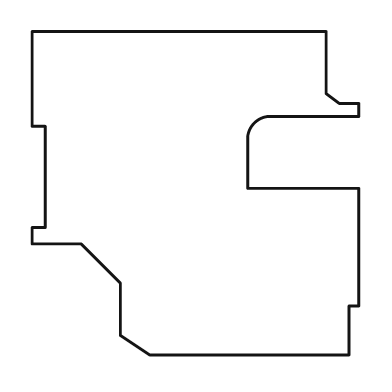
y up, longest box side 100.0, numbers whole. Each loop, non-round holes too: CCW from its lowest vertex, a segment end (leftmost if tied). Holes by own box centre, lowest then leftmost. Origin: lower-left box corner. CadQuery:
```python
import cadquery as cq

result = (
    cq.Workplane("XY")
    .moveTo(36.0, 0.0)
    .lineTo(97.0, 0.0)
    .lineTo(97.0, 15.0)
    .lineTo(100.0, 15.0)
    .lineTo(100.0, 51.0)
    .lineTo(66.0, 51.0)
    .lineTo(66.0, 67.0)
    .threePointArc((68.0, 71.0), (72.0, 73.0))
    .lineTo(100.0, 73.0)
    .lineTo(100.0, 77.0)
    .lineTo(94.0, 77.0)
    .lineTo(90.0, 80.0)
    .lineTo(90.0, 99.0)
    .lineTo(0.0, 99.0)
    .lineTo(0.0, 70.0)
    .lineTo(4.0, 70.0)
    .lineTo(4.0, 39.0)
    .lineTo(0.0, 39.0)
    .lineTo(0.0, 34.0)
    .lineTo(15.0, 34.0)
    .lineTo(27.0, 22.0)
    .lineTo(27.0, 6.0)
    .close()
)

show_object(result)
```